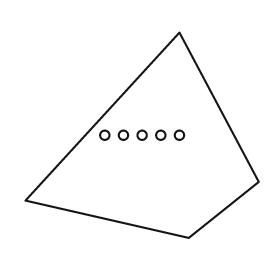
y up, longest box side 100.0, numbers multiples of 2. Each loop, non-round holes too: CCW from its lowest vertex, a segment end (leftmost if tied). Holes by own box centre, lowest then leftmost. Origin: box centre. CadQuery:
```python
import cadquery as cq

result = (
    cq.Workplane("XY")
    .moveTo(20.0, -44.0)
    .lineTo(50.0, -20.0)
    .lineTo(16.0, 44.0)
    .lineTo(-50.0, -28.0)
    .close()
    .moveTo(-16.0, 0.0)
    .circle(2.0)
    .moveTo(-8.0, 0.0)
    .circle(2.0)
    .moveTo(0.0, 0.0)
    .circle(2.0)
    .moveTo(8.0, 0.0)
    .circle(2.0)
    .moveTo(16.0, 0.0)
    .circle(2.0)
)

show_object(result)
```